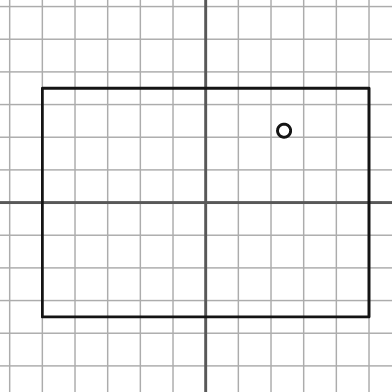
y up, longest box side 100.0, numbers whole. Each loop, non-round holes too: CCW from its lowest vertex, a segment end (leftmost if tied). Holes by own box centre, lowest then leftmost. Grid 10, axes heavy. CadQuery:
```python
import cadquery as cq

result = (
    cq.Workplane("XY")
    .moveTo(-50.0, -35.0)
    .lineTo(50.0, -35.0)
    .lineTo(50.0, 35.0)
    .lineTo(-50.0, 35.0)
    .close()
    .moveTo(24.0, 22.0)
    .circle(2.0)
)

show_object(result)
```